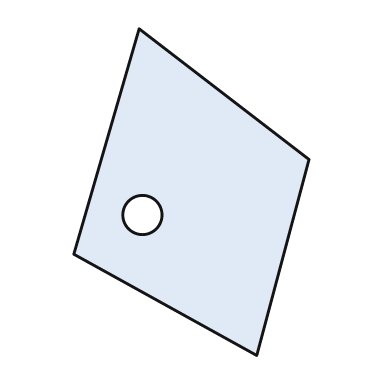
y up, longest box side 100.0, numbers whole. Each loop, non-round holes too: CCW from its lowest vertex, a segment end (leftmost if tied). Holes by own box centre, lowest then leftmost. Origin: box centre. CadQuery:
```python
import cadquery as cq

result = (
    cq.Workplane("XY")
    .moveTo(20.0, -50.0)
    .lineTo(36.0, 10.0)
    .lineTo(-16.0, 50.0)
    .lineTo(-36.0, -19.0)
    .close()
    .moveTo(-15.0, -7.0)
    .circle(6.0)
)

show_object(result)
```